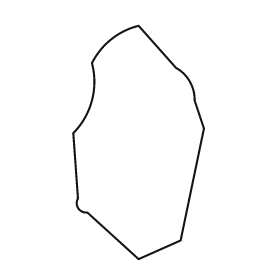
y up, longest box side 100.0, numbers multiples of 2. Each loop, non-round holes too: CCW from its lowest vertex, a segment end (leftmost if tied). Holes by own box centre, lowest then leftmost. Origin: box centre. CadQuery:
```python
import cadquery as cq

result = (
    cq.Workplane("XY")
    .moveTo(0.0, -50.0)
    .lineTo(18.0, -42.0)
    .lineTo(28.0, 6.0)
    .lineTo(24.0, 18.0)
    .threePointArc((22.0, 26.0), (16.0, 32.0))
    .lineTo(0.0, 50.0)
    .threePointArc((-12.0, 44.0), (-20.0, 34.0))
    .threePointArc((-20.0, 18.0), (-28.0, 4.0))
    .lineTo(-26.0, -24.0)
    .threePointArc((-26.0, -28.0), (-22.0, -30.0))
    .close()
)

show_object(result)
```